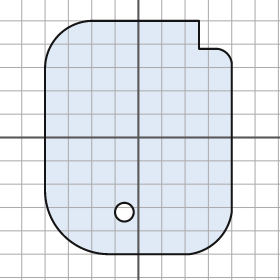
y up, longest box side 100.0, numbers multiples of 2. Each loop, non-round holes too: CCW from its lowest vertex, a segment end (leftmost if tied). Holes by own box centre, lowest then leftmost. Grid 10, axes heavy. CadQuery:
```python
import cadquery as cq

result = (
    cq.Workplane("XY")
    .moveTo(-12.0, -50.0)
    .lineTo(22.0, -50.0)
    .threePointArc((34.0, -44.0), (40.0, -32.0))
    .lineTo(40.0, 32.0)
    .threePointArc((38.0, 36.0), (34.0, 38.0))
    .lineTo(26.0, 38.0)
    .lineTo(26.0, 50.0)
    .lineTo(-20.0, 50.0)
    .threePointArc((-34.0, 44.0), (-40.0, 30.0))
    .lineTo(-40.0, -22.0)
    .threePointArc((-32.0, -42.0), (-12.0, -50.0))
    .close()
    .moveTo(-6.0, -32.0)
    .circle(4.0)
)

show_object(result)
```